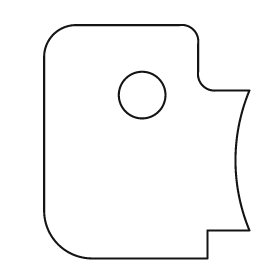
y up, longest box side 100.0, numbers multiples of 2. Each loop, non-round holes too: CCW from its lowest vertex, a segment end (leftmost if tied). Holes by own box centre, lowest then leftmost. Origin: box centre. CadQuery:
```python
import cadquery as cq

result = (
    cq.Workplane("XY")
    .moveTo(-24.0, -50.0)
    .lineTo(26.0, -50.0)
    .lineTo(26.0, -38.0)
    .lineTo(44.0, -38.0)
    .threePointArc((38.0, -8.0), (44.0, 22.0))
    .lineTo(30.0, 22.0)
    .threePointArc((24.0, 24.0), (22.0, 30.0))
    .lineTo(22.0, 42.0)
    .threePointArc((20.0, 48.0), (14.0, 50.0))
    .lineTo(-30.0, 50.0)
    .threePointArc((-40.0, 46.0), (-44.0, 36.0))
    .lineTo(-44.0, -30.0)
    .threePointArc((-38.0, -44.0), (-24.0, -50.0))
    .close()
    .moveTo(-2.0, 20.0)
    .circle(10.0)
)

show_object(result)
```